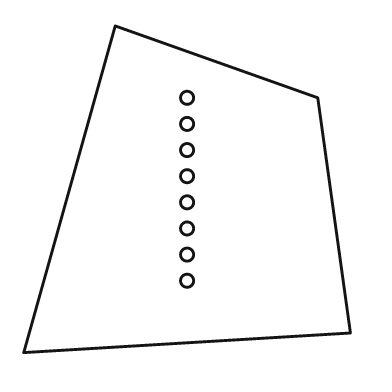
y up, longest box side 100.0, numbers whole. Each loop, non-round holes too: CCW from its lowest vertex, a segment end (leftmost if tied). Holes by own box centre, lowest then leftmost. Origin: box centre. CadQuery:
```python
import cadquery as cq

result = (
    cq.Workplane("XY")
    .moveTo(-50.0, -50.0)
    .lineTo(50.0, -44.0)
    .lineTo(40.0, 28.0)
    .lineTo(-22.0, 50.0)
    .close()
    .moveTo(0.0, -28.0)
    .circle(2.0)
    .moveTo(0.0, -20.0)
    .circle(2.0)
    .moveTo(0.0, -12.0)
    .circle(2.0)
    .moveTo(0.0, -4.0)
    .circle(2.0)
    .moveTo(0.0, 4.0)
    .circle(2.0)
    .moveTo(0.0, 12.0)
    .circle(2.0)
    .moveTo(0.0, 20.0)
    .circle(2.0)
    .moveTo(0.0, 28.0)
    .circle(2.0)
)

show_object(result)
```